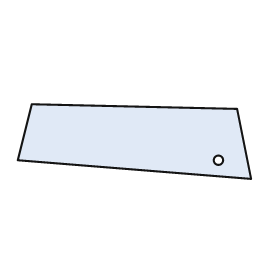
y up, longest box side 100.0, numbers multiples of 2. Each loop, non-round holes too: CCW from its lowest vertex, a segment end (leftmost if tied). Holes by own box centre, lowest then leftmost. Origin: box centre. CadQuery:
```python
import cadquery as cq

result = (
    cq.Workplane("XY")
    .moveTo(50.0, -16.0)
    .lineTo(44.0, 14.0)
    .lineTo(-44.0, 16.0)
    .lineTo(-50.0, -8.0)
    .close()
    .moveTo(36.0, -8.0)
    .circle(2.0)
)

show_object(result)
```